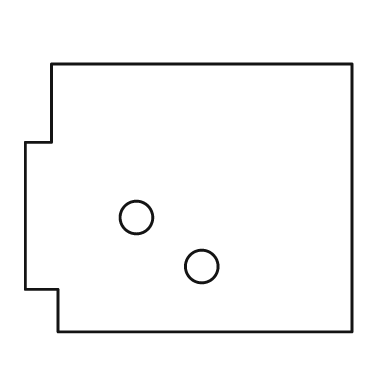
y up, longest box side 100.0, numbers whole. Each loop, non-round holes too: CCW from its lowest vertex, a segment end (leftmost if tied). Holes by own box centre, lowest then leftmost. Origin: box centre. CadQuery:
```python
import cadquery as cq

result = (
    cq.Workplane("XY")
    .moveTo(-40.0, -41.0)
    .lineTo(50.0, -41.0)
    .lineTo(50.0, 41.0)
    .lineTo(-42.0, 41.0)
    .lineTo(-42.0, 17.0)
    .lineTo(-50.0, 17.0)
    .lineTo(-50.0, -28.0)
    .lineTo(-40.0, -28.0)
    .close()
    .moveTo(4.0, -21.0)
    .circle(5.0)
    .moveTo(-16.0, -6.0)
    .circle(5.0)
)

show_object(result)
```